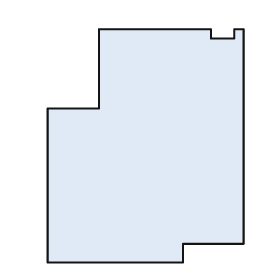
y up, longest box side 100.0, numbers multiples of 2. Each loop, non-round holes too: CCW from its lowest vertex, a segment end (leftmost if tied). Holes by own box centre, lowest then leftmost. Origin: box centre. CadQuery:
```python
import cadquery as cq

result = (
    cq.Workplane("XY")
    .moveTo(-42.0, -50.0)
    .lineTo(16.0, -50.0)
    .lineTo(16.0, -42.0)
    .lineTo(42.0, -42.0)
    .lineTo(42.0, 50.0)
    .lineTo(38.0, 50.0)
    .lineTo(38.0, 46.0)
    .lineTo(28.0, 46.0)
    .lineTo(28.0, 50.0)
    .lineTo(-20.0, 50.0)
    .lineTo(-20.0, 16.0)
    .lineTo(-42.0, 16.0)
    .close()
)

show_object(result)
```